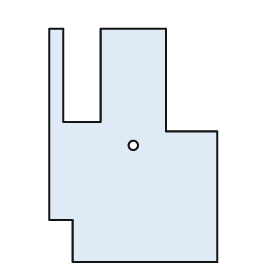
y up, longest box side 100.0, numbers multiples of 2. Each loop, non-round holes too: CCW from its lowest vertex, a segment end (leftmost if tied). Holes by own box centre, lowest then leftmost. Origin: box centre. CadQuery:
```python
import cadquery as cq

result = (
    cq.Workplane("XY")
    .moveTo(-26.0, -50.0)
    .lineTo(36.0, -50.0)
    .lineTo(36.0, 6.0)
    .lineTo(14.0, 6.0)
    .lineTo(14.0, 50.0)
    .lineTo(-14.0, 50.0)
    .lineTo(-14.0, 10.0)
    .lineTo(-30.0, 10.0)
    .lineTo(-30.0, 50.0)
    .lineTo(-36.0, 50.0)
    .lineTo(-36.0, -32.0)
    .lineTo(-26.0, -32.0)
    .close()
    .moveTo(0.0, 0.0)
    .circle(2.0)
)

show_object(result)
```